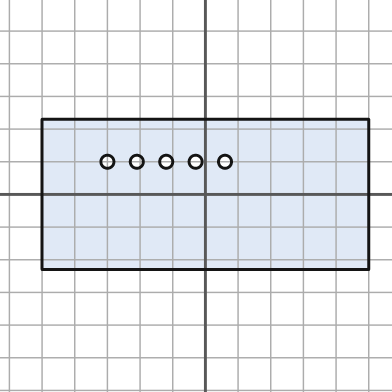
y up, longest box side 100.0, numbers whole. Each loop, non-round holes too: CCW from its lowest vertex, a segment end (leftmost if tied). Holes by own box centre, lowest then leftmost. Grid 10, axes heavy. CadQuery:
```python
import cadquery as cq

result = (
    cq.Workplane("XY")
    .moveTo(-50.0, -23.0)
    .lineTo(50.0, -23.0)
    .lineTo(50.0, 23.0)
    .lineTo(-50.0, 23.0)
    .close()
    .moveTo(-30.0, 10.0)
    .circle(2.0)
    .moveTo(-21.0, 10.0)
    .circle(2.0)
    .moveTo(-12.0, 10.0)
    .circle(2.0)
    .moveTo(-3.0, 10.0)
    .circle(2.0)
    .moveTo(6.0, 10.0)
    .circle(2.0)
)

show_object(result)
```